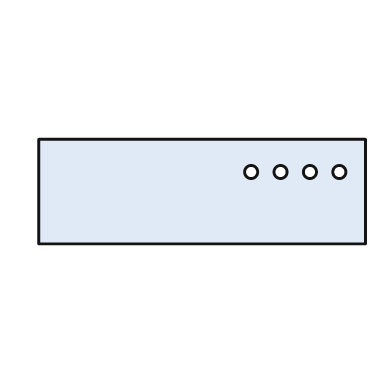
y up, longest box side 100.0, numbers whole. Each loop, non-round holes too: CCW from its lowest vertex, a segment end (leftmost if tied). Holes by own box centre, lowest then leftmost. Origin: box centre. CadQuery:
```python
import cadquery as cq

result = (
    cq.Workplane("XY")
    .moveTo(-50.0, -16.0)
    .lineTo(50.0, -16.0)
    .lineTo(50.0, 16.0)
    .lineTo(-50.0, 16.0)
    .close()
    .moveTo(15.0, 6.0)
    .circle(2.0)
    .moveTo(24.0, 6.0)
    .circle(2.0)
    .moveTo(33.0, 6.0)
    .circle(2.0)
    .moveTo(42.0, 6.0)
    .circle(2.0)
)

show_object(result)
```